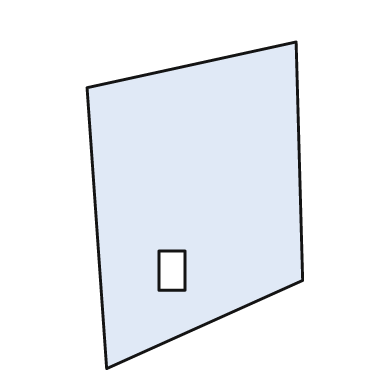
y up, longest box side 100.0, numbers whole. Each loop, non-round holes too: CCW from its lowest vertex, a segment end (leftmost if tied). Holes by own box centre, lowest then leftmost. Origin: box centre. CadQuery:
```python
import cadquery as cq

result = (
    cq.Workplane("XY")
    .moveTo(-27.0, -50.0)
    .lineTo(33.0, -23.0)
    .lineTo(31.0, 50.0)
    .lineTo(-33.0, 36.0)
    .close()
    .moveTo(-11.0, -26.0)
    .lineTo(-3.0, -26.0)
    .lineTo(-3.0, -14.0)
    .lineTo(-11.0, -14.0)
    .close()
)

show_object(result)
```